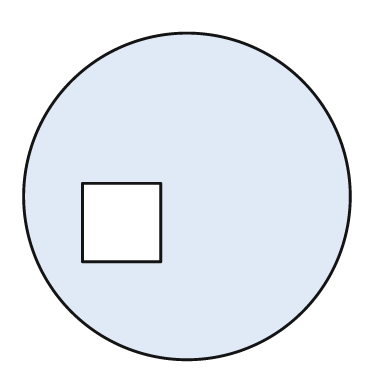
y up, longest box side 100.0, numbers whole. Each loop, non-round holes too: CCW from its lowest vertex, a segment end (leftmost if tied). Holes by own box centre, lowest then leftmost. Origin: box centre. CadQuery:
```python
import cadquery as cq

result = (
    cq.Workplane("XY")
    .moveTo(0.0, 0.0)
    .circle(50.0)
    .moveTo(-32.0, -20.0)
    .lineTo(-8.0, -20.0)
    .lineTo(-8.0, 4.0)
    .lineTo(-32.0, 4.0)
    .close()
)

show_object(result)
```